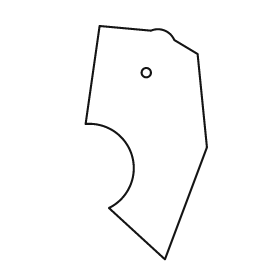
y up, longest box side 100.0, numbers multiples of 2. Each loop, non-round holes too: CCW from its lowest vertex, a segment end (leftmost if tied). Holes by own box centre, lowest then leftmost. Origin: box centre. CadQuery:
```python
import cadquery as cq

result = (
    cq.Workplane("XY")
    .moveTo(8.0, -50.0)
    .lineTo(26.0, -2.0)
    .lineTo(22.0, 38.0)
    .lineTo(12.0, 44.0)
    .threePointArc((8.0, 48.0), (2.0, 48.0))
    .lineTo(-20.0, 50.0)
    .lineTo(-26.0, 8.0)
    .threePointArc((-6.0, -6.0), (-16.0, -28.0))
    .close()
    .moveTo(0.0, 30.0)
    .circle(2.0)
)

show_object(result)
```